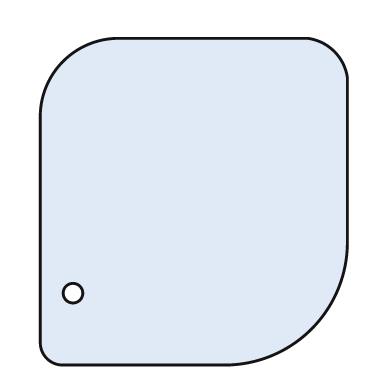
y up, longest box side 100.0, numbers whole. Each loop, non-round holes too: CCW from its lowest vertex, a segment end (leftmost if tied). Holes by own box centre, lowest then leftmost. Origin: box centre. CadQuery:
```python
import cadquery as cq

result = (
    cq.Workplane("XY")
    .moveTo(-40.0, -50.0)
    .lineTo(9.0, -50.0)
    .threePointArc((36.0, -39.0), (47.0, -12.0))
    .lineTo(47.0, 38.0)
    .threePointArc((43.0, 46.0), (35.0, 50.0))
    .lineTo(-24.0, 50.0)
    .threePointArc((-40.0, 43.0), (-47.0, 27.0))
    .lineTo(-47.0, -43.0)
    .threePointArc((-45.0, -48.0), (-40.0, -50.0))
    .close()
    .moveTo(-37.0, -28.0)
    .circle(3.0)
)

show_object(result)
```